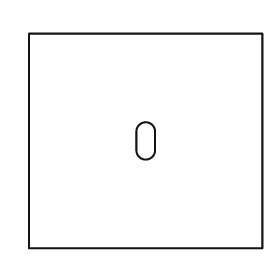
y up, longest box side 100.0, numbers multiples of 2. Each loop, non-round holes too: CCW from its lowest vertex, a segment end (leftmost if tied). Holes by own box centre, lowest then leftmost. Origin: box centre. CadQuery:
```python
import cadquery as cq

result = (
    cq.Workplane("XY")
    .moveTo(-50.0, -46.0)
    .lineTo(50.0, -46.0)
    .lineTo(50.0, 46.0)
    .lineTo(-50.0, 46.0)
    .close()
    .moveTo(-4.0, -4.0)
    .threePointArc((0.0, -8.0), (4.0, -4.0))
    .lineTo(4.0, 4.0)
    .threePointArc((0.0, 8.0), (-4.0, 4.0))
    .close()
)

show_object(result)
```